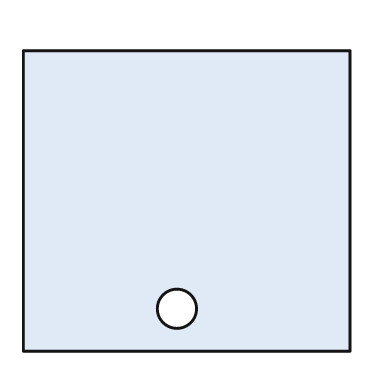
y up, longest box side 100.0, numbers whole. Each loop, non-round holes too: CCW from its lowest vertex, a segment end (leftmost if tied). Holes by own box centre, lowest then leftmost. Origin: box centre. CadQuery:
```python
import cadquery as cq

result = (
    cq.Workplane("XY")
    .moveTo(-50.0, -46.0)
    .lineTo(50.0, -46.0)
    .lineTo(50.0, 46.0)
    .lineTo(-50.0, 46.0)
    .close()
    .moveTo(-3.0, -33.0)
    .circle(6.0)
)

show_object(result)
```